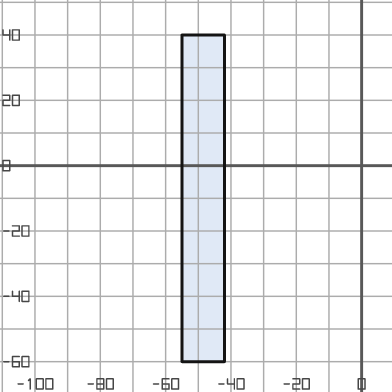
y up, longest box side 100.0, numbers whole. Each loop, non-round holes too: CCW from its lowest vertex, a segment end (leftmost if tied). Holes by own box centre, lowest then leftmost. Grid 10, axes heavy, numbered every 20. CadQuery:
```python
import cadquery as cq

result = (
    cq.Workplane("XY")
    .moveTo(-55.0, -60.0)
    .lineTo(-42.0, -60.0)
    .lineTo(-42.0, 40.0)
    .lineTo(-55.0, 40.0)
    .close()
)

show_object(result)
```